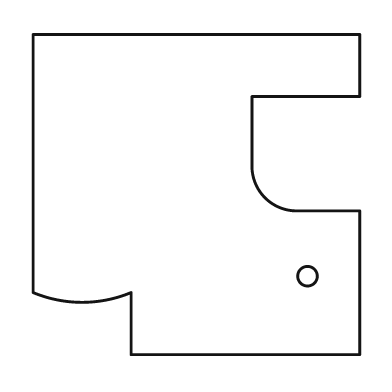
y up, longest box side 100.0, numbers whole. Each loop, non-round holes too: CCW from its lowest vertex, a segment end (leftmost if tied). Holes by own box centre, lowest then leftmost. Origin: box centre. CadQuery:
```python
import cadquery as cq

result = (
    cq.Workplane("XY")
    .moveTo(-20.0, -49.0)
    .lineTo(50.0, -49.0)
    .lineTo(50.0, -5.0)
    .lineTo(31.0, -5.0)
    .threePointArc((21.0, -1.0), (17.0, 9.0))
    .lineTo(17.0, 30.0)
    .lineTo(50.0, 30.0)
    .lineTo(50.0, 49.0)
    .lineTo(-50.0, 49.0)
    .lineTo(-50.0, -30.0)
    .threePointArc((-35.0, -33.0), (-20.0, -30.0))
    .close()
    .moveTo(34.0, -25.0)
    .circle(3.0)
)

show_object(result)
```